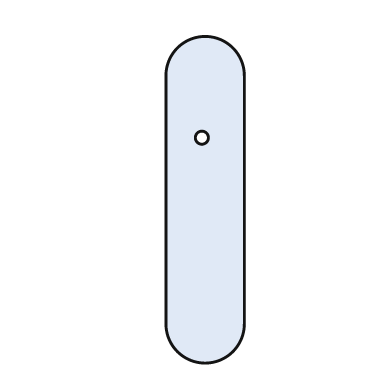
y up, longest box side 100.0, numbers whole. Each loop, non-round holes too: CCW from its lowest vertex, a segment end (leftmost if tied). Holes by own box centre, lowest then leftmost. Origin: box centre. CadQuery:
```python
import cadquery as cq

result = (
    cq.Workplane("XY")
    .moveTo(-12.0, -38.0)
    .threePointArc((0.0, -50.0), (12.0, -38.0))
    .lineTo(12.0, 38.0)
    .threePointArc((0.0, 50.0), (-12.0, 38.0))
    .close()
    .moveTo(-1.0, 19.0)
    .circle(2.0)
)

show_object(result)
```